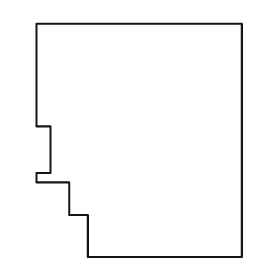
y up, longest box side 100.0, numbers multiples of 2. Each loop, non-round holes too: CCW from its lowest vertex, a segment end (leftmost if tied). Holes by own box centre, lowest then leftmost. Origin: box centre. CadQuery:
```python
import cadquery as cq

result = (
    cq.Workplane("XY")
    .moveTo(-22.0, -50.0)
    .lineTo(44.0, -50.0)
    .lineTo(44.0, 50.0)
    .lineTo(-44.0, 50.0)
    .lineTo(-44.0, 6.0)
    .lineTo(-38.0, 6.0)
    .lineTo(-38.0, -14.0)
    .lineTo(-44.0, -14.0)
    .lineTo(-44.0, -18.0)
    .lineTo(-30.0, -18.0)
    .lineTo(-30.0, -32.0)
    .lineTo(-22.0, -32.0)
    .close()
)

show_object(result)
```